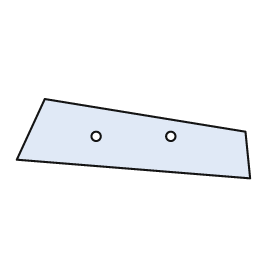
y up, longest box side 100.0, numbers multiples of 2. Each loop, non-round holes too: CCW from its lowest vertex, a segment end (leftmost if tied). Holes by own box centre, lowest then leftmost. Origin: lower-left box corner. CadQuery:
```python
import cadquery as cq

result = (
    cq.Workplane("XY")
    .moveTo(100.0, 0.0)
    .lineTo(98.0, 20.0)
    .lineTo(12.0, 34.0)
    .lineTo(0.0, 8.0)
    .close()
    .moveTo(34.0, 18.0)
    .circle(2.0)
    .moveTo(66.0, 18.0)
    .circle(2.0)
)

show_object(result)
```